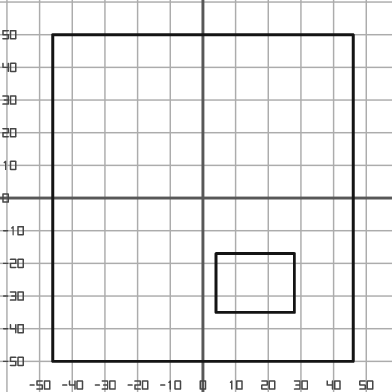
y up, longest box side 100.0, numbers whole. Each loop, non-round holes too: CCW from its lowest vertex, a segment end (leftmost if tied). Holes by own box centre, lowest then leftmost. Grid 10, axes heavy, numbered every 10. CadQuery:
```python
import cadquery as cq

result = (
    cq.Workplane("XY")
    .moveTo(-46.0, -50.0)
    .lineTo(46.0, -50.0)
    .lineTo(46.0, 50.0)
    .lineTo(-46.0, 50.0)
    .close()
    .moveTo(4.0, -35.0)
    .lineTo(28.0, -35.0)
    .lineTo(28.0, -17.0)
    .lineTo(4.0, -17.0)
    .close()
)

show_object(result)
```